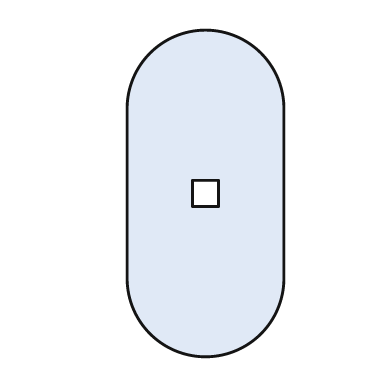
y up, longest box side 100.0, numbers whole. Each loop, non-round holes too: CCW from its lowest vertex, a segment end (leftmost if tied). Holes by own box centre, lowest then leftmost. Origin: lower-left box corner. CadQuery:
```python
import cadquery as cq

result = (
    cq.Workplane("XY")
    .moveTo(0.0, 24.0)
    .threePointArc((24.0, 0.0), (48.0, 24.0))
    .lineTo(48.0, 76.0)
    .threePointArc((24.0, 100.0), (0.0, 76.0))
    .close()
    .moveTo(20.0, 46.0)
    .lineTo(28.0, 46.0)
    .lineTo(28.0, 54.0)
    .lineTo(20.0, 54.0)
    .close()
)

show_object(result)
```